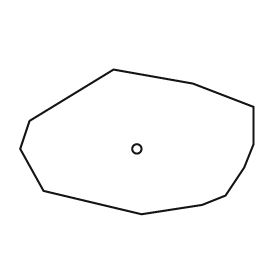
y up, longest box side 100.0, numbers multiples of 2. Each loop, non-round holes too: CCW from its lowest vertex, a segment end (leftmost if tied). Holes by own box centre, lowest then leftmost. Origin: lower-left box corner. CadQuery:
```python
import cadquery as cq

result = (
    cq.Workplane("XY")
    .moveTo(52.0, 0.0)
    .lineTo(78.0, 4.0)
    .lineTo(88.0, 8.0)
    .lineTo(96.0, 20.0)
    .lineTo(100.0, 30.0)
    .lineTo(100.0, 46.0)
    .lineTo(74.0, 56.0)
    .lineTo(40.0, 62.0)
    .lineTo(4.0, 40.0)
    .lineTo(0.0, 28.0)
    .lineTo(10.0, 10.0)
    .close()
    .moveTo(50.0, 28.0)
    .circle(2.0)
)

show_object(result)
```